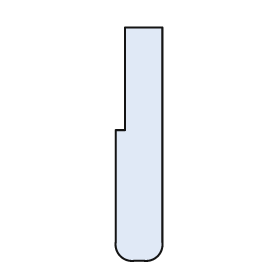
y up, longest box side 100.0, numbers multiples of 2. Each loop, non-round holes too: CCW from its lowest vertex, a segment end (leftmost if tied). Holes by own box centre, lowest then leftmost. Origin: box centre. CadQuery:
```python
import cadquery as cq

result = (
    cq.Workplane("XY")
    .moveTo(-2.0, -50.0)
    .lineTo(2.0, -50.0)
    .threePointArc((8.0, -48.0), (10.0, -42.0))
    .lineTo(10.0, 50.0)
    .lineTo(-6.0, 50.0)
    .lineTo(-6.0, 6.0)
    .lineTo(-10.0, 6.0)
    .lineTo(-10.0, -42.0)
    .threePointArc((-8.0, -48.0), (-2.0, -50.0))
    .close()
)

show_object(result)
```